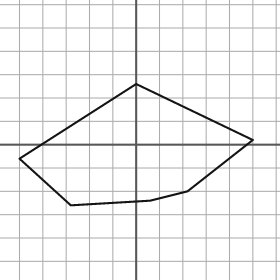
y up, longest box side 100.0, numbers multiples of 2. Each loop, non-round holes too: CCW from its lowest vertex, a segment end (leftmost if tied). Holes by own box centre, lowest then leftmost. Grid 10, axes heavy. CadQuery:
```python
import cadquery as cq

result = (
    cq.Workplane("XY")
    .moveTo(-28.0, -26.0)
    .lineTo(6.0, -24.0)
    .lineTo(22.0, -20.0)
    .lineTo(50.0, 2.0)
    .lineTo(0.0, 26.0)
    .lineTo(-50.0, -6.0)
    .close()
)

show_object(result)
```